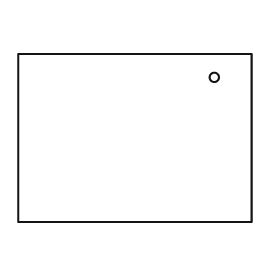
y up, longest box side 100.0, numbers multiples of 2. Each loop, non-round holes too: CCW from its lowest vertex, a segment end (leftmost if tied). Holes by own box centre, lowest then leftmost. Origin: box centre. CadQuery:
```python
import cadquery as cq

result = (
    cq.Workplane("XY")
    .moveTo(-50.0, -36.0)
    .lineTo(50.0, -36.0)
    .lineTo(50.0, 36.0)
    .lineTo(-50.0, 36.0)
    .close()
    .moveTo(34.0, 26.0)
    .circle(2.0)
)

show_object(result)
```